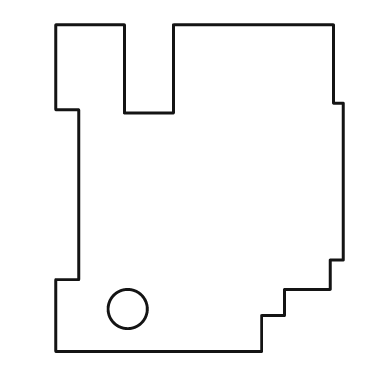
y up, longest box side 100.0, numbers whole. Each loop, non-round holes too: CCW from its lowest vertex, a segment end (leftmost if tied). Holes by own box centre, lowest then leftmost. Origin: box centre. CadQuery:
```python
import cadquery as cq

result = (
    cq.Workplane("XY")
    .moveTo(-44.0, -50.0)
    .lineTo(19.0, -50.0)
    .lineTo(19.0, -39.0)
    .lineTo(26.0, -39.0)
    .lineTo(26.0, -31.0)
    .lineTo(40.0, -31.0)
    .lineTo(40.0, -22.0)
    .lineTo(44.0, -22.0)
    .lineTo(44.0, 26.0)
    .lineTo(41.0, 26.0)
    .lineTo(41.0, 50.0)
    .lineTo(-8.0, 50.0)
    .lineTo(-8.0, 23.0)
    .lineTo(-23.0, 23.0)
    .lineTo(-23.0, 50.0)
    .lineTo(-44.0, 50.0)
    .lineTo(-44.0, 24.0)
    .lineTo(-37.0, 24.0)
    .lineTo(-37.0, -28.0)
    .lineTo(-44.0, -28.0)
    .close()
    .moveTo(-22.0, -37.0)
    .circle(6.0)
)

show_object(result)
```